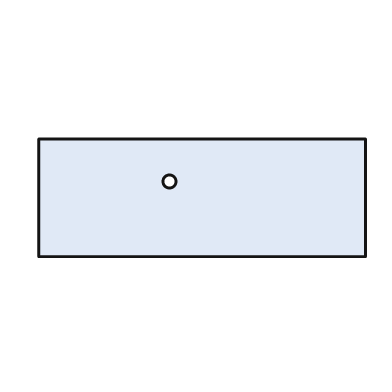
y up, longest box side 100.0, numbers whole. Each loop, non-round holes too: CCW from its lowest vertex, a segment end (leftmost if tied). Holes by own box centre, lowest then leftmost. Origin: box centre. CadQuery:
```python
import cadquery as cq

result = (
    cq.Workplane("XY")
    .moveTo(-50.0, -18.0)
    .lineTo(50.0, -18.0)
    .lineTo(50.0, 18.0)
    .lineTo(-50.0, 18.0)
    .close()
    .moveTo(-10.0, 5.0)
    .circle(2.0)
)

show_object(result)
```